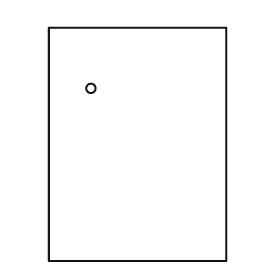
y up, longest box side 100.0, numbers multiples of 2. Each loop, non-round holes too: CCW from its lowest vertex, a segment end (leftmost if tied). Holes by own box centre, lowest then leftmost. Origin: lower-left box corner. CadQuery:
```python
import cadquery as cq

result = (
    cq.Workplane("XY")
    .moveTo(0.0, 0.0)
    .lineTo(76.0, 0.0)
    .lineTo(76.0, 100.0)
    .lineTo(0.0, 100.0)
    .close()
    .moveTo(18.0, 74.0)
    .circle(2.0)
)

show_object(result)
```